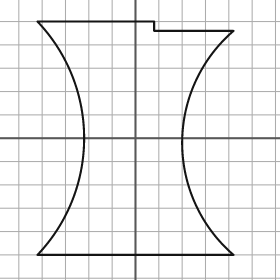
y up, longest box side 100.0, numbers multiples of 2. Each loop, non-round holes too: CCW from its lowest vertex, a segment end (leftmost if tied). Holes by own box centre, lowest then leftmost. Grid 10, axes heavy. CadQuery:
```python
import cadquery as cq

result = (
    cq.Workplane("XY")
    .moveTo(-42.0, -50.0)
    .lineTo(42.0, -50.0)
    .threePointArc((20.0, -2.0), (42.0, 46.0))
    .lineTo(8.0, 46.0)
    .lineTo(8.0, 50.0)
    .lineTo(-42.0, 50.0)
    .threePointArc((-22.0, 0.0), (-42.0, -50.0))
    .close()
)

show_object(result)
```